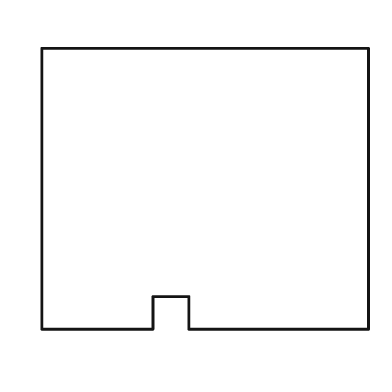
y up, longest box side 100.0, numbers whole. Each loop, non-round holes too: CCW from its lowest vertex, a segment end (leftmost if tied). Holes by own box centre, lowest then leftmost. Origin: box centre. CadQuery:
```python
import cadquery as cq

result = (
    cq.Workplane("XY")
    .moveTo(-50.0, -43.0)
    .lineTo(-16.0, -43.0)
    .lineTo(-16.0, -33.0)
    .lineTo(-5.0, -33.0)
    .lineTo(-5.0, -43.0)
    .lineTo(50.0, -43.0)
    .lineTo(50.0, 43.0)
    .lineTo(-50.0, 43.0)
    .close()
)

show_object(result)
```